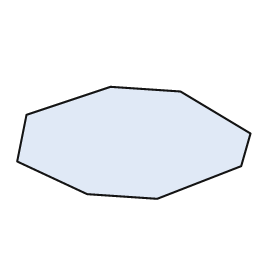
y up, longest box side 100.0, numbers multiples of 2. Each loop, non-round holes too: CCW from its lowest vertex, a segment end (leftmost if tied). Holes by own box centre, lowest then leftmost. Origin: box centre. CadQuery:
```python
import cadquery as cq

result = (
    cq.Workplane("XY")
    .moveTo(10.0, -24.0)
    .lineTo(46.0, -10.0)
    .lineTo(50.0, 4.0)
    .lineTo(20.0, 22.0)
    .lineTo(-10.0, 24.0)
    .lineTo(-46.0, 12.0)
    .lineTo(-50.0, -8.0)
    .lineTo(-20.0, -22.0)
    .close()
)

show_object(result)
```